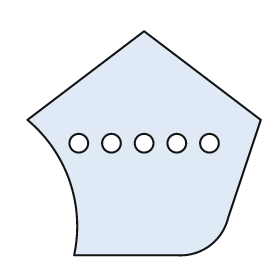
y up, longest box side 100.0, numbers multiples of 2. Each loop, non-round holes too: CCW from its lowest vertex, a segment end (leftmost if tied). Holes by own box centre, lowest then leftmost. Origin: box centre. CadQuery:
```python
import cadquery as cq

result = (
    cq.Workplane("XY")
    .moveTo(-30.0, -48.0)
    .lineTo(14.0, -48.0)
    .threePointArc((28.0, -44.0), (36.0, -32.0))
    .lineTo(50.0, 10.0)
    .lineTo(0.0, 48.0)
    .lineTo(-50.0, 10.0)
    .threePointArc((-32.0, -16.0), (-30.0, -48.0))
    .close()
    .moveTo(-28.0, 0.0)
    .circle(4.0)
    .moveTo(-14.0, 0.0)
    .circle(4.0)
    .moveTo(0.0, 0.0)
    .circle(4.0)
    .moveTo(14.0, 0.0)
    .circle(4.0)
    .moveTo(28.0, 0.0)
    .circle(4.0)
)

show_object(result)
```